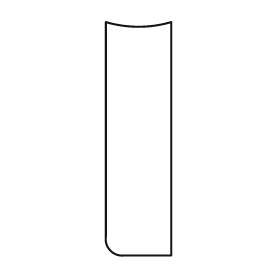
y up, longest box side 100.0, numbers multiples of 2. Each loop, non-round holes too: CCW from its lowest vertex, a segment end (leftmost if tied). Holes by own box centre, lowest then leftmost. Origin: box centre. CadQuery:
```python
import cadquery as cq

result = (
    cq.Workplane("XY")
    .moveTo(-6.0, -50.0)
    .lineTo(14.0, -50.0)
    .lineTo(14.0, 50.0)
    .threePointArc((0.0, 48.0), (-14.0, 50.0))
    .lineTo(-14.0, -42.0)
    .threePointArc((-12.0, -48.0), (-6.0, -50.0))
    .close()
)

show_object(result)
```